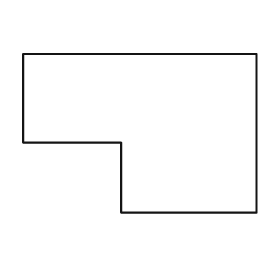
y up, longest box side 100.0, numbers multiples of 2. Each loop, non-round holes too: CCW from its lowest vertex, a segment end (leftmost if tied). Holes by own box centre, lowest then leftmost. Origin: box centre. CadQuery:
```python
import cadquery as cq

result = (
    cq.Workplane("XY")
    .moveTo(-8.0, -34.0)
    .lineTo(50.0, -34.0)
    .lineTo(50.0, 34.0)
    .lineTo(-50.0, 34.0)
    .lineTo(-50.0, -4.0)
    .lineTo(-8.0, -4.0)
    .close()
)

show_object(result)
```